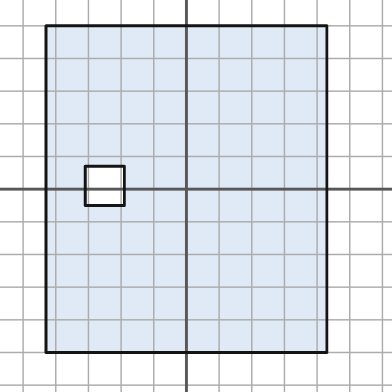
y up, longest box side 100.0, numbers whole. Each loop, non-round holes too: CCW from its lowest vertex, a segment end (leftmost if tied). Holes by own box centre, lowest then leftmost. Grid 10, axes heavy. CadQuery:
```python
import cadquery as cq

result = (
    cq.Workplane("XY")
    .moveTo(-43.0, -50.0)
    .lineTo(43.0, -50.0)
    .lineTo(43.0, 50.0)
    .lineTo(-43.0, 50.0)
    .close()
    .moveTo(-31.0, -5.0)
    .lineTo(-19.0, -5.0)
    .lineTo(-19.0, 7.0)
    .lineTo(-31.0, 7.0)
    .close()
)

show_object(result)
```